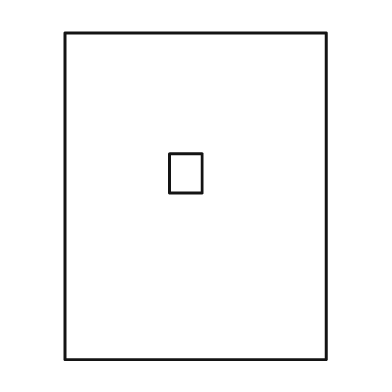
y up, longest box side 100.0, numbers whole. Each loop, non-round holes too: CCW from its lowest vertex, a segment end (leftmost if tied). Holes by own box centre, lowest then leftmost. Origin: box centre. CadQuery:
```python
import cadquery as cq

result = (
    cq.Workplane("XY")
    .moveTo(-40.0, -50.0)
    .lineTo(40.0, -50.0)
    .lineTo(40.0, 50.0)
    .lineTo(-40.0, 50.0)
    .close()
    .moveTo(-8.0, 1.0)
    .lineTo(2.0, 1.0)
    .lineTo(2.0, 13.0)
    .lineTo(-8.0, 13.0)
    .close()
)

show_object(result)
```